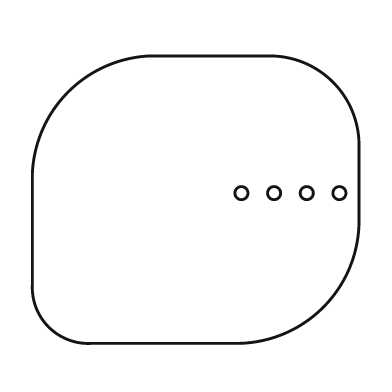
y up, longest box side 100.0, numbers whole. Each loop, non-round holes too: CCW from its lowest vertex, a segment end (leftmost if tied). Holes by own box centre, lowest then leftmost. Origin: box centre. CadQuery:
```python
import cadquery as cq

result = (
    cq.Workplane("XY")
    .moveTo(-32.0, -44.0)
    .lineTo(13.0, -44.0)
    .threePointArc((39.0, -33.0), (50.0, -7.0))
    .lineTo(50.0, 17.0)
    .threePointArc((42.0, 36.0), (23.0, 44.0))
    .lineTo(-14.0, 44.0)
    .threePointArc((-39.0, 33.0), (-50.0, 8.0))
    .lineTo(-50.0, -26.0)
    .threePointArc((-45.0, -39.0), (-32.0, -44.0))
    .close()
    .moveTo(14.0, 2.0)
    .circle(2.0)
    .moveTo(24.0, 2.0)
    .circle(2.0)
    .moveTo(34.0, 2.0)
    .circle(2.0)
    .moveTo(44.0, 2.0)
    .circle(2.0)
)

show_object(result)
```